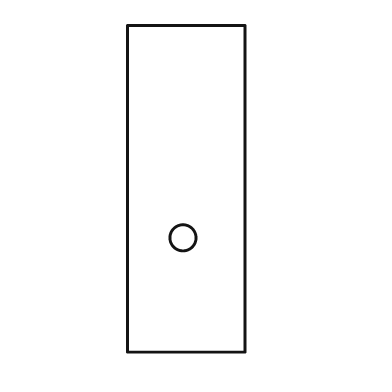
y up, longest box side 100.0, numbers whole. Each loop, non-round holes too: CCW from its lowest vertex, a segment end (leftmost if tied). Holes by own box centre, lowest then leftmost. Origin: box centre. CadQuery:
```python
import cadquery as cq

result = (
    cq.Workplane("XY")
    .moveTo(-18.0, -50.0)
    .lineTo(18.0, -50.0)
    .lineTo(18.0, 50.0)
    .lineTo(-18.0, 50.0)
    .close()
    .moveTo(-1.0, -15.0)
    .circle(4.0)
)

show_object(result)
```